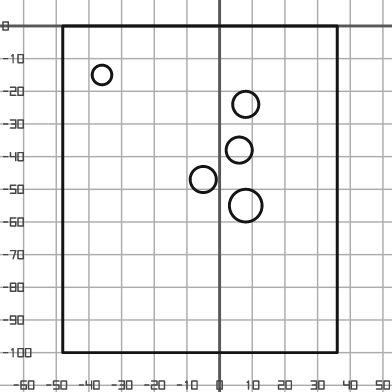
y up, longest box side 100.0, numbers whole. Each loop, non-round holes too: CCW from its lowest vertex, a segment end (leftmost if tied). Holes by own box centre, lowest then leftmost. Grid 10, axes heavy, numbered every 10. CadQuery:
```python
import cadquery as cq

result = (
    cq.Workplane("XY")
    .moveTo(-48.0, -100.0)
    .lineTo(36.0, -100.0)
    .lineTo(36.0, 0.0)
    .lineTo(-48.0, 0.0)
    .close()
    .moveTo(8.0, -55.0)
    .circle(5.0)
    .moveTo(-5.0, -47.0)
    .circle(4.0)
    .moveTo(6.0, -38.0)
    .circle(4.0)
    .moveTo(8.0, -24.0)
    .circle(4.0)
    .moveTo(-36.0, -15.0)
    .circle(3.0)
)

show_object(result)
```